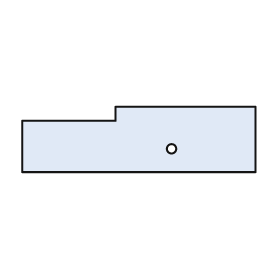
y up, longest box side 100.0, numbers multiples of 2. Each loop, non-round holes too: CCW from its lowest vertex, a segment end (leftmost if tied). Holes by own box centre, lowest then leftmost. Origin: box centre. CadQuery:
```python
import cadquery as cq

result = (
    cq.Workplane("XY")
    .moveTo(-50.0, -14.0)
    .lineTo(50.0, -14.0)
    .lineTo(50.0, 14.0)
    .lineTo(-10.0, 14.0)
    .lineTo(-10.0, 8.0)
    .lineTo(-50.0, 8.0)
    .close()
    .moveTo(14.0, -4.0)
    .circle(2.0)
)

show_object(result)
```